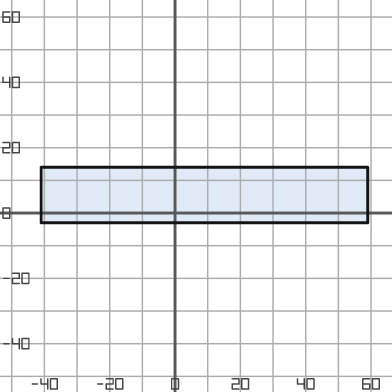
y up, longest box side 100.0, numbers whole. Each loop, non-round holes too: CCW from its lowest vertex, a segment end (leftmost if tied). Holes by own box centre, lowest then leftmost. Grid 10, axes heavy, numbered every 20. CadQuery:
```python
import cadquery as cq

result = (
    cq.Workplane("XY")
    .moveTo(-41.0, -3.0)
    .lineTo(59.0, -3.0)
    .lineTo(59.0, 14.0)
    .lineTo(-41.0, 14.0)
    .close()
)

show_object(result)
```